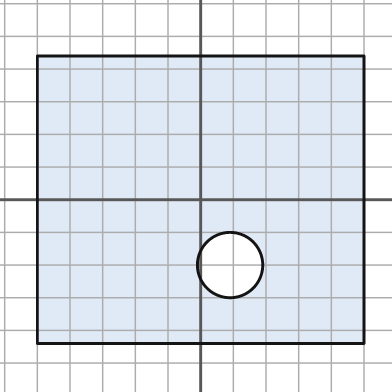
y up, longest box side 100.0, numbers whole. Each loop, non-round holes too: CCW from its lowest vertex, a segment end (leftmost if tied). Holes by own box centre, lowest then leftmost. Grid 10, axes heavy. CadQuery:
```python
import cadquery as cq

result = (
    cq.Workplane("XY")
    .moveTo(-50.0, -44.0)
    .lineTo(50.0, -44.0)
    .lineTo(50.0, 44.0)
    .lineTo(-50.0, 44.0)
    .close()
    .moveTo(9.0, -20.0)
    .circle(10.0)
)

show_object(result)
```